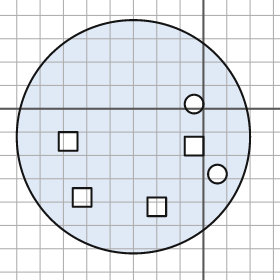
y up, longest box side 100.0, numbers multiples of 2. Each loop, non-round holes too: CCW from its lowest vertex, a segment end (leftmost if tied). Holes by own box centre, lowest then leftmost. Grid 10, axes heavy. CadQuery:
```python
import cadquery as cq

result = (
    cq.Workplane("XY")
    .moveTo(-30.0, -12.0)
    .circle(50.0)
    .moveTo(-24.0, -46.0)
    .lineTo(-16.0, -46.0)
    .lineTo(-16.0, -38.0)
    .lineTo(-24.0, -38.0)
    .close()
    .moveTo(-56.0, -42.0)
    .lineTo(-48.0, -42.0)
    .lineTo(-48.0, -34.0)
    .lineTo(-56.0, -34.0)
    .close()
    .moveTo(6.0, -28.0)
    .circle(4.0)
    .moveTo(-8.0, -20.0)
    .lineTo(0.0, -20.0)
    .lineTo(0.0, -12.0)
    .lineTo(-8.0, -12.0)
    .close()
    .moveTo(-62.0, -18.0)
    .lineTo(-54.0, -18.0)
    .lineTo(-54.0, -10.0)
    .lineTo(-62.0, -10.0)
    .close()
    .moveTo(-4.0, 2.0)
    .circle(4.0)
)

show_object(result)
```